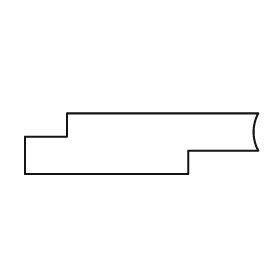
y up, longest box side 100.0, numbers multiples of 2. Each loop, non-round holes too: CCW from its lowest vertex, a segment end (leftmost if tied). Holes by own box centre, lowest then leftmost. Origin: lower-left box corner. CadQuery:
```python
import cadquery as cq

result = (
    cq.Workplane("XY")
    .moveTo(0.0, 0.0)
    .lineTo(70.0, 0.0)
    .lineTo(70.0, 10.0)
    .lineTo(100.0, 10.0)
    .threePointArc((98.0, 18.0), (100.0, 26.0))
    .lineTo(18.0, 26.0)
    .lineTo(18.0, 16.0)
    .lineTo(0.0, 16.0)
    .close()
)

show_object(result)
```